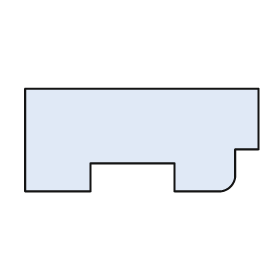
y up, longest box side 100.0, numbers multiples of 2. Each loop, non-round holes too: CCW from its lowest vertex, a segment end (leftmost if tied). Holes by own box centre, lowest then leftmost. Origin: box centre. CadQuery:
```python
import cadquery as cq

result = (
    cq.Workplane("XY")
    .moveTo(-50.0, -22.0)
    .lineTo(-22.0, -22.0)
    .lineTo(-22.0, -10.0)
    .lineTo(14.0, -10.0)
    .lineTo(14.0, -22.0)
    .lineTo(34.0, -22.0)
    .threePointArc((38.0, -20.0), (40.0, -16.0))
    .lineTo(40.0, -4.0)
    .lineTo(50.0, -4.0)
    .lineTo(50.0, 22.0)
    .lineTo(-50.0, 22.0)
    .close()
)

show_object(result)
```